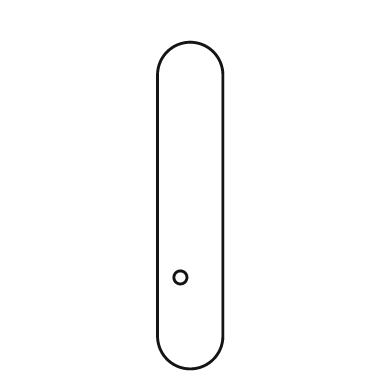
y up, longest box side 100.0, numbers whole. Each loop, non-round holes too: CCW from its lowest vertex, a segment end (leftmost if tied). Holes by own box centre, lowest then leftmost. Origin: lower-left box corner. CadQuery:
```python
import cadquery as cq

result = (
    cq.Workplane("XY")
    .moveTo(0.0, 10.0)
    .threePointArc((10.0, 0.0), (20.0, 10.0))
    .lineTo(20.0, 90.0)
    .threePointArc((10.0, 100.0), (0.0, 90.0))
    .close()
    .moveTo(7.0, 28.0)
    .circle(2.0)
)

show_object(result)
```